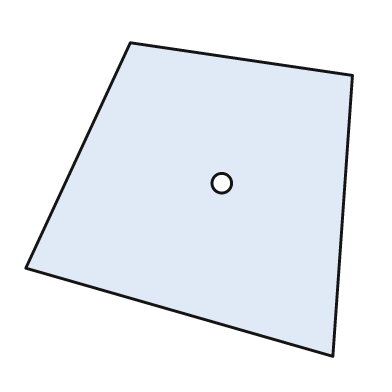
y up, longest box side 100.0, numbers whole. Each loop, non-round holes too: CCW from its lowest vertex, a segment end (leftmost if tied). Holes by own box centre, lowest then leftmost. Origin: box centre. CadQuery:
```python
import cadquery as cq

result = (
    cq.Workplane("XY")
    .moveTo(44.0, -48.0)
    .lineTo(50.0, 38.0)
    .lineTo(-18.0, 48.0)
    .lineTo(-50.0, -21.0)
    .close()
    .moveTo(10.0, 5.0)
    .circle(3.0)
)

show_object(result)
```